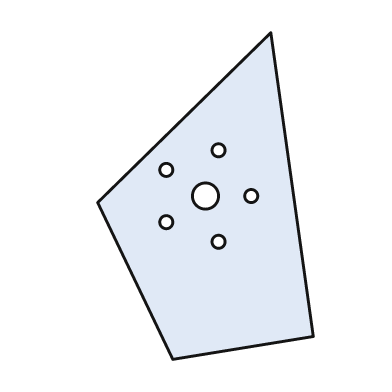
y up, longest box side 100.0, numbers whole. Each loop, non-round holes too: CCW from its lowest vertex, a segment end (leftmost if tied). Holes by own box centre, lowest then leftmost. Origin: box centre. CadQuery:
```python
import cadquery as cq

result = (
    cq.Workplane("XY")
    .moveTo(-10.0, -50.0)
    .lineTo(33.0, -43.0)
    .lineTo(20.0, 50.0)
    .lineTo(-33.0, -2.0)
    .close()
    .moveTo(4.0, -14.0)
    .circle(2.0)
    .moveTo(-12.0, -8.0)
    .circle(2.0)
    .moveTo(0.0, 0.0)
    .circle(4.0)
    .moveTo(14.0, 0.0)
    .circle(2.0)
    .moveTo(-12.0, 8.0)
    .circle(2.0)
    .moveTo(4.0, 14.0)
    .circle(2.0)
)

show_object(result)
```